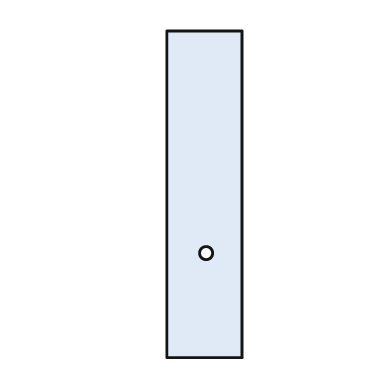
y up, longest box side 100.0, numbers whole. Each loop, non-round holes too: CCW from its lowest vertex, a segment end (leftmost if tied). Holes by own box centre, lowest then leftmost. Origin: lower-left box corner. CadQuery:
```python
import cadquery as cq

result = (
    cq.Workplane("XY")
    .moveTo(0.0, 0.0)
    .lineTo(23.0, 0.0)
    .lineTo(23.0, 100.0)
    .lineTo(0.0, 100.0)
    .close()
    .moveTo(12.0, 32.0)
    .circle(2.0)
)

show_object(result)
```